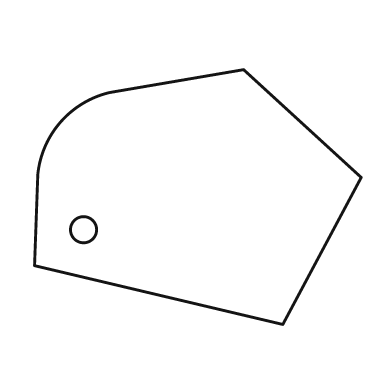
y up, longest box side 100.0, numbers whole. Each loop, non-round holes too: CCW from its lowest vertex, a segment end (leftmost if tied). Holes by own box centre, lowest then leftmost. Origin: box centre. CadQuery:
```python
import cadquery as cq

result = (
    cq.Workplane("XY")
    .moveTo(26.0, -39.0)
    .lineTo(50.0, 6.0)
    .lineTo(14.0, 39.0)
    .lineTo(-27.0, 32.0)
    .threePointArc((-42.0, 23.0), (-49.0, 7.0))
    .lineTo(-50.0, -21.0)
    .close()
    .moveTo(-35.0, -10.0)
    .circle(4.0)
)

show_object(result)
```